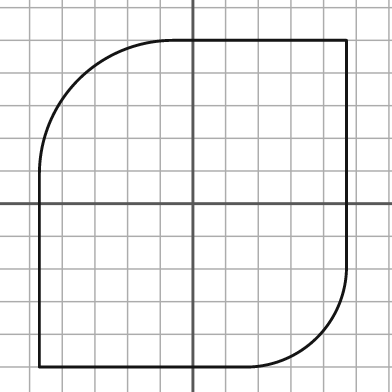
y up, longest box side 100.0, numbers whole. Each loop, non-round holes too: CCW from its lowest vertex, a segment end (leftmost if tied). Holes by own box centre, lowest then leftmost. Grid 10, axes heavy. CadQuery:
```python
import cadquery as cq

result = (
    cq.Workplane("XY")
    .moveTo(-47.0, -50.0)
    .lineTo(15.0, -50.0)
    .threePointArc((38.0, -41.0), (47.0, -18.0))
    .lineTo(47.0, 50.0)
    .lineTo(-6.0, 50.0)
    .threePointArc((-35.0, 38.0), (-47.0, 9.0))
    .close()
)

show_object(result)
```